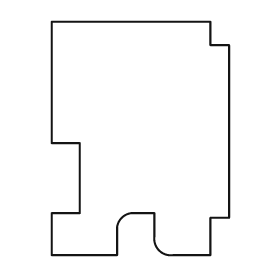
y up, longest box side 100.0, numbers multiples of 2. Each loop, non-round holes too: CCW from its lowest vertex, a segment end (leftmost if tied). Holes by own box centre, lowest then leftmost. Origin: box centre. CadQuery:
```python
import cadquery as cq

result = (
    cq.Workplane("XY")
    .moveTo(-38.0, -50.0)
    .lineTo(-10.0, -50.0)
    .lineTo(-10.0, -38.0)
    .threePointArc((-8.0, -34.0), (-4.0, -32.0))
    .lineTo(6.0, -32.0)
    .lineTo(6.0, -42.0)
    .threePointArc((8.0, -48.0), (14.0, -50.0))
    .lineTo(30.0, -50.0)
    .lineTo(30.0, -34.0)
    .lineTo(38.0, -34.0)
    .lineTo(38.0, 40.0)
    .lineTo(30.0, 40.0)
    .lineTo(30.0, 50.0)
    .lineTo(-38.0, 50.0)
    .lineTo(-38.0, -2.0)
    .lineTo(-26.0, -2.0)
    .lineTo(-26.0, -32.0)
    .lineTo(-38.0, -32.0)
    .close()
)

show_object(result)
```